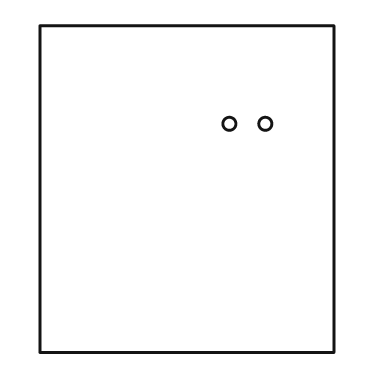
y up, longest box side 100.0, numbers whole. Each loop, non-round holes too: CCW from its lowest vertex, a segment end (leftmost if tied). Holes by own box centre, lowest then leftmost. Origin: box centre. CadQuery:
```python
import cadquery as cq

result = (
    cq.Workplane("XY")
    .moveTo(-45.0, -50.0)
    .lineTo(45.0, -50.0)
    .lineTo(45.0, 50.0)
    .lineTo(-45.0, 50.0)
    .close()
    .moveTo(13.0, 20.0)
    .circle(2.0)
    .moveTo(24.0, 20.0)
    .circle(2.0)
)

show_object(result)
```